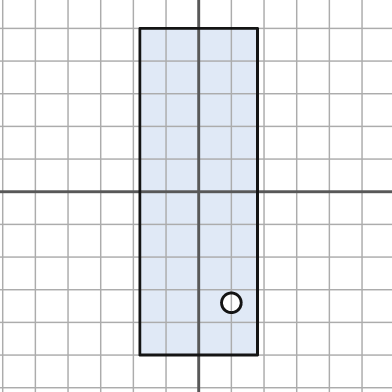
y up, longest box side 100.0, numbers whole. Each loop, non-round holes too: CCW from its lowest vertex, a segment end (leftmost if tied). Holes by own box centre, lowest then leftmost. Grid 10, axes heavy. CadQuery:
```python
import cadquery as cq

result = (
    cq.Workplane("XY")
    .moveTo(-18.0, -50.0)
    .lineTo(18.0, -50.0)
    .lineTo(18.0, 50.0)
    .lineTo(-18.0, 50.0)
    .close()
    .moveTo(10.0, -34.0)
    .circle(3.0)
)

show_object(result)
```